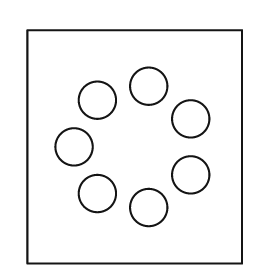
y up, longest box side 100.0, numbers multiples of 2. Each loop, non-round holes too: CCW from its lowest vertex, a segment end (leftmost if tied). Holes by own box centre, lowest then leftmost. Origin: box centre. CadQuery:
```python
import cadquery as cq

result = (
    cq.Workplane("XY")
    .moveTo(-46.0, -50.0)
    .lineTo(46.0, -50.0)
    .lineTo(46.0, 50.0)
    .lineTo(-46.0, 50.0)
    .close()
    .moveTo(6.0, -26.0)
    .circle(8.0)
    .moveTo(-16.0, -20.0)
    .circle(8.0)
    .moveTo(24.0, -12.0)
    .circle(8.0)
    .moveTo(-26.0, 0.0)
    .circle(8.0)
    .moveTo(24.0, 12.0)
    .circle(8.0)
    .moveTo(-16.0, 20.0)
    .circle(8.0)
    .moveTo(6.0, 26.0)
    .circle(8.0)
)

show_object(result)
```